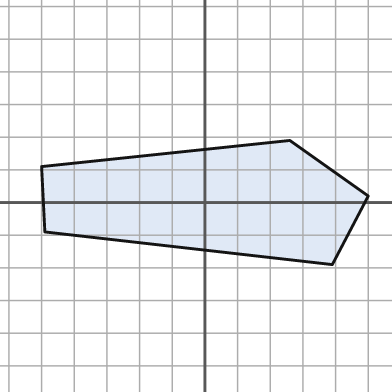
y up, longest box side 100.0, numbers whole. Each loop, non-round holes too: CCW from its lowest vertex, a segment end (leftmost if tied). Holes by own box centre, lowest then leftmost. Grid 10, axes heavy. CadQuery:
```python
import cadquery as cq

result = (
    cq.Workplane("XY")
    .moveTo(39.0, -19.0)
    .lineTo(50.0, 2.0)
    .lineTo(26.0, 19.0)
    .lineTo(-50.0, 11.0)
    .lineTo(-49.0, -9.0)
    .close()
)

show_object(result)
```